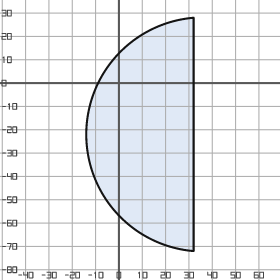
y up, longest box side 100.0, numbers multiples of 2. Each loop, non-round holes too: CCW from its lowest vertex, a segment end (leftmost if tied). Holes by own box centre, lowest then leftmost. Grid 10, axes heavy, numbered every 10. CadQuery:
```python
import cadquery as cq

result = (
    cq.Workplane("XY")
    .moveTo(32.0, -72.0)
    .lineTo(32.0, 28.0)
    .threePointArc((-14.0, -22.0), (32.0, -72.0))
    .close()
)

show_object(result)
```